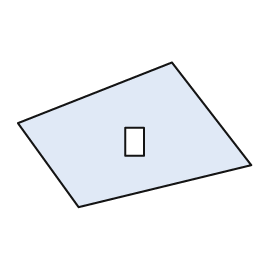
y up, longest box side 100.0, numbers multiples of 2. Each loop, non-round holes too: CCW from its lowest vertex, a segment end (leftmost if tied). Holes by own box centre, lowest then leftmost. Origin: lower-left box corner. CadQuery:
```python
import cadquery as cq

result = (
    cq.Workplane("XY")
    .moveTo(26.0, 0.0)
    .lineTo(100.0, 18.0)
    .lineTo(66.0, 62.0)
    .lineTo(0.0, 36.0)
    .close()
    .moveTo(46.0, 22.0)
    .lineTo(54.0, 22.0)
    .lineTo(54.0, 34.0)
    .lineTo(46.0, 34.0)
    .close()
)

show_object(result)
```